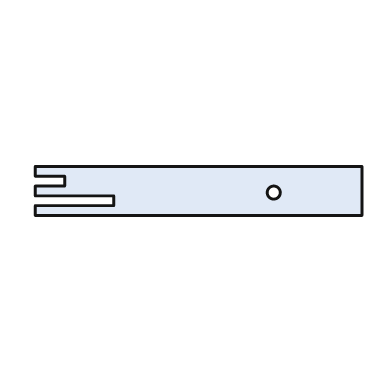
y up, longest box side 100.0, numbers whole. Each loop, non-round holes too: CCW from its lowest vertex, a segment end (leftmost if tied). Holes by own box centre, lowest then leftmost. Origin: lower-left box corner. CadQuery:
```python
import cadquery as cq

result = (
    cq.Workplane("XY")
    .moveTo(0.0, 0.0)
    .lineTo(100.0, 0.0)
    .lineTo(100.0, 15.0)
    .lineTo(0.0, 15.0)
    .lineTo(0.0, 12.0)
    .lineTo(9.0, 12.0)
    .lineTo(9.0, 9.0)
    .lineTo(0.0, 9.0)
    .lineTo(0.0, 6.0)
    .lineTo(24.0, 6.0)
    .lineTo(24.0, 3.0)
    .lineTo(0.0, 3.0)
    .close()
    .moveTo(73.0, 7.0)
    .circle(2.0)
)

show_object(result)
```